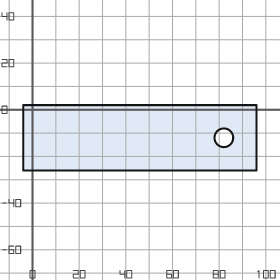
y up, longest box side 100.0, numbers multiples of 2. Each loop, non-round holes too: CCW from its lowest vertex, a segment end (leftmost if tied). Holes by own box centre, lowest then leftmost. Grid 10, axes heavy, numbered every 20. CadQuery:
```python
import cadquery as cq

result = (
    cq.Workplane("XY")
    .moveTo(-4.0, -26.0)
    .lineTo(96.0, -26.0)
    .lineTo(96.0, 2.0)
    .lineTo(-4.0, 2.0)
    .close()
    .moveTo(82.0, -12.0)
    .circle(4.0)
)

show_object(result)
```